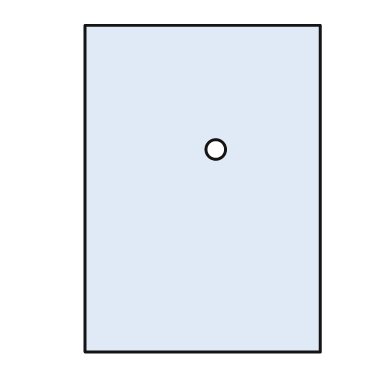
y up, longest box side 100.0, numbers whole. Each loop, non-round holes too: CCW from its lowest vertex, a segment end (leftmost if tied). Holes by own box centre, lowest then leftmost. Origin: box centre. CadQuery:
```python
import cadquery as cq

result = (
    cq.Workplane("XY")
    .moveTo(-36.0, -50.0)
    .lineTo(36.0, -50.0)
    .lineTo(36.0, 50.0)
    .lineTo(-36.0, 50.0)
    .close()
    .moveTo(4.0, 12.0)
    .circle(3.0)
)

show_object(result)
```